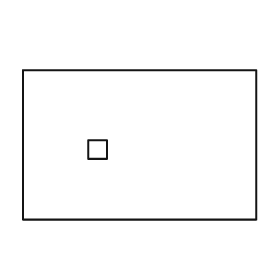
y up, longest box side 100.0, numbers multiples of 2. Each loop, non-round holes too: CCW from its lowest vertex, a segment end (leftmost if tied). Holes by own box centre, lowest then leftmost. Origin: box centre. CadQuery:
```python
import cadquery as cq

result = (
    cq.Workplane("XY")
    .moveTo(-50.0, -32.0)
    .lineTo(50.0, -32.0)
    .lineTo(50.0, 32.0)
    .lineTo(-50.0, 32.0)
    .close()
    .moveTo(-22.0, -6.0)
    .lineTo(-14.0, -6.0)
    .lineTo(-14.0, 2.0)
    .lineTo(-22.0, 2.0)
    .close()
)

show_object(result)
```